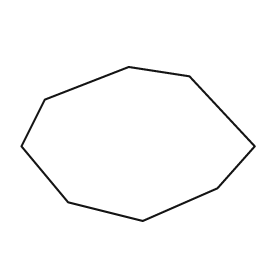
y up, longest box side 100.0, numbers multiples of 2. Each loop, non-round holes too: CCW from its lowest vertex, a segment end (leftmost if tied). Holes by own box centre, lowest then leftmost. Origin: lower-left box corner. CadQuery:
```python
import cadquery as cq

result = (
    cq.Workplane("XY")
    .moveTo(52.0, 0.0)
    .lineTo(84.0, 14.0)
    .lineTo(100.0, 32.0)
    .lineTo(72.0, 62.0)
    .lineTo(46.0, 66.0)
    .lineTo(10.0, 52.0)
    .lineTo(0.0, 32.0)
    .lineTo(20.0, 8.0)
    .close()
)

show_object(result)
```